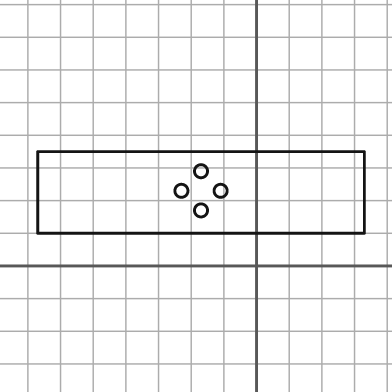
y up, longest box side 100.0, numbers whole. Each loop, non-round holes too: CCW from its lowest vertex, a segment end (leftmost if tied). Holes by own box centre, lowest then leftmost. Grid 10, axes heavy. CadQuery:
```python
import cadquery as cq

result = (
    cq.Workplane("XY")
    .moveTo(-67.0, 10.0)
    .lineTo(33.0, 10.0)
    .lineTo(33.0, 35.0)
    .lineTo(-67.0, 35.0)
    .close()
    .moveTo(-17.0, 17.0)
    .circle(2.0)
    .moveTo(-23.0, 23.0)
    .circle(2.0)
    .moveTo(-11.0, 23.0)
    .circle(2.0)
    .moveTo(-17.0, 29.0)
    .circle(2.0)
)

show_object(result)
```